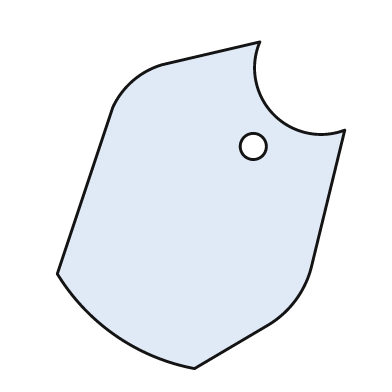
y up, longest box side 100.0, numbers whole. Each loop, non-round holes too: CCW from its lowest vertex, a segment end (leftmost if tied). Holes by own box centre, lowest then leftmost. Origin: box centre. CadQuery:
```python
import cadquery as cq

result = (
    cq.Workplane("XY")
    .moveTo(-2.0, -50.0)
    .lineTo(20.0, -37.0)
    .threePointArc((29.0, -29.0), (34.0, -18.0))
    .lineTo(44.0, 23.0)
    .threePointArc((22.0, 28.0), (18.0, 50.0))
    .lineTo(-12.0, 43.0)
    .threePointArc((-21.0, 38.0), (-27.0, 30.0))
    .lineTo(-44.0, -21.0)
    .threePointArc((-26.0, -40.0), (-2.0, -50.0))
    .close()
    .moveTo(16.0, 18.0)
    .circle(4.0)
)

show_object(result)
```